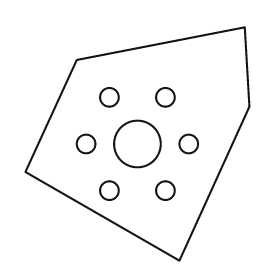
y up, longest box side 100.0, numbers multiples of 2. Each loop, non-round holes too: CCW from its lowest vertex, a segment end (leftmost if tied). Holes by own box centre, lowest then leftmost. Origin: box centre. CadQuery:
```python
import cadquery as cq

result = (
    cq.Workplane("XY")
    .moveTo(18.0, -50.0)
    .lineTo(48.0, 16.0)
    .lineTo(46.0, 50.0)
    .lineTo(-26.0, 36.0)
    .lineTo(-48.0, -12.0)
    .close()
    .moveTo(-12.0, -20.0)
    .circle(4.0)
    .moveTo(12.0, -20.0)
    .circle(4.0)
    .moveTo(-22.0, 0.0)
    .circle(4.0)
    .moveTo(0.0, 0.0)
    .circle(10.0)
    .moveTo(22.0, 0.0)
    .circle(4.0)
    .moveTo(-12.0, 20.0)
    .circle(4.0)
    .moveTo(12.0, 20.0)
    .circle(4.0)
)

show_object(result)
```